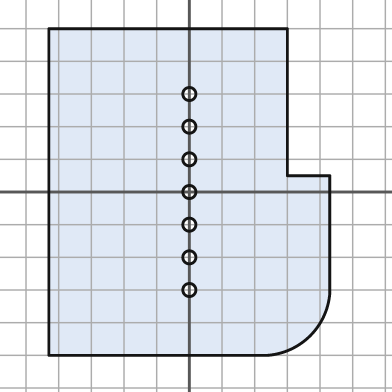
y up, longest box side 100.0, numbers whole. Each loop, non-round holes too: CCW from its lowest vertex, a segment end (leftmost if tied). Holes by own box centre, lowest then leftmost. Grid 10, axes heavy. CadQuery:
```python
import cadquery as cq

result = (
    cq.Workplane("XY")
    .moveTo(-43.0, -50.0)
    .lineTo(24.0, -50.0)
    .threePointArc((37.0, -44.0), (43.0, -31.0))
    .lineTo(43.0, 5.0)
    .lineTo(30.0, 5.0)
    .lineTo(30.0, 50.0)
    .lineTo(-43.0, 50.0)
    .close()
    .moveTo(0.0, -30.0)
    .circle(2.0)
    .moveTo(0.0, -20.0)
    .circle(2.0)
    .moveTo(0.0, -10.0)
    .circle(2.0)
    .moveTo(0.0, 0.0)
    .circle(2.0)
    .moveTo(0.0, 10.0)
    .circle(2.0)
    .moveTo(0.0, 20.0)
    .circle(2.0)
    .moveTo(0.0, 30.0)
    .circle(2.0)
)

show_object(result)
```